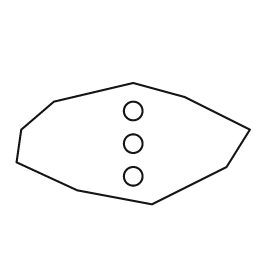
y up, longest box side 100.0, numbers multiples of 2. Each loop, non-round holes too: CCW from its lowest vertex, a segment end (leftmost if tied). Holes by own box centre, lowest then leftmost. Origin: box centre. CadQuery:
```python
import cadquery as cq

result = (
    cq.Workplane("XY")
    .moveTo(8.0, -26.0)
    .lineTo(40.0, -10.0)
    .lineTo(50.0, 6.0)
    .lineTo(22.0, 20.0)
    .lineTo(0.0, 26.0)
    .lineTo(-34.0, 18.0)
    .lineTo(-48.0, 6.0)
    .lineTo(-50.0, -8.0)
    .lineTo(-24.0, -20.0)
    .close()
    .moveTo(0.0, -14.0)
    .circle(4.0)
    .moveTo(0.0, 0.0)
    .circle(4.0)
    .moveTo(0.0, 14.0)
    .circle(4.0)
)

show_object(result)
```